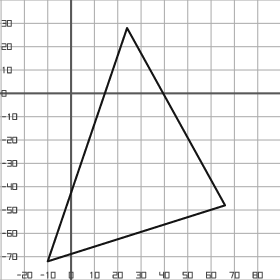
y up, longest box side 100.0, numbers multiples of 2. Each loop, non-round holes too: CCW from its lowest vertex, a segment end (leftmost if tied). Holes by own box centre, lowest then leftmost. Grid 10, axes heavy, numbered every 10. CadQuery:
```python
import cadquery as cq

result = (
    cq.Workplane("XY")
    .moveTo(-10.0, -72.0)
    .lineTo(66.0, -48.0)
    .lineTo(24.0, 28.0)
    .close()
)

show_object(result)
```